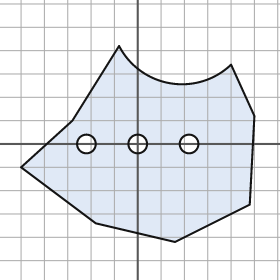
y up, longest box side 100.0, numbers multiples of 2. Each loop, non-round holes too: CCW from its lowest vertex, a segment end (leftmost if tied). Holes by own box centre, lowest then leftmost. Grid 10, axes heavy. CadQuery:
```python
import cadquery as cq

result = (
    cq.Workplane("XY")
    .moveTo(16.0, -42.0)
    .lineTo(48.0, -26.0)
    .lineTo(50.0, 12.0)
    .lineTo(40.0, 34.0)
    .threePointArc((14.0, 26.0), (-8.0, 42.0))
    .lineTo(-28.0, 10.0)
    .lineTo(-50.0, -10.0)
    .lineTo(-18.0, -34.0)
    .close()
    .moveTo(-22.0, 0.0)
    .circle(4.0)
    .moveTo(0.0, 0.0)
    .circle(4.0)
    .moveTo(22.0, 0.0)
    .circle(4.0)
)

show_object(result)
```